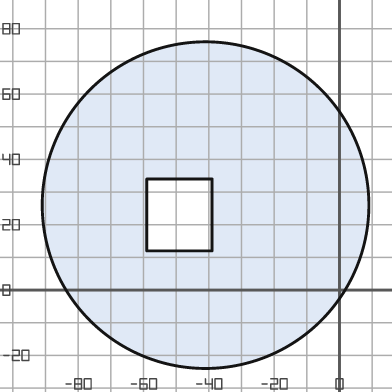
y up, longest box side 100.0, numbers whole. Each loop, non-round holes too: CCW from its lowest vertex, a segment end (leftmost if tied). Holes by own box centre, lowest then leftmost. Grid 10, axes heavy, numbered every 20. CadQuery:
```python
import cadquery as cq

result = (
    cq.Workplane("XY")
    .moveTo(-41.0, 26.0)
    .circle(50.0)
    .moveTo(-59.0, 12.0)
    .lineTo(-39.0, 12.0)
    .lineTo(-39.0, 34.0)
    .lineTo(-59.0, 34.0)
    .close()
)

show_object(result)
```